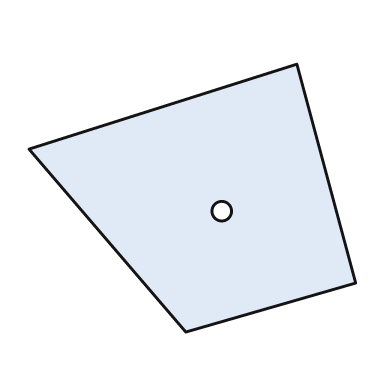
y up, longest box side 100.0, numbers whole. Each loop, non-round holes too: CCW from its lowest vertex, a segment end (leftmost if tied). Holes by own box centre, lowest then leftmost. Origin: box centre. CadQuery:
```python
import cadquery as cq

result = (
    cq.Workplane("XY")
    .moveTo(-2.0, -41.0)
    .lineTo(50.0, -26.0)
    .lineTo(32.0, 41.0)
    .lineTo(-50.0, 15.0)
    .close()
    .moveTo(9.0, -4.0)
    .circle(3.0)
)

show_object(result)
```